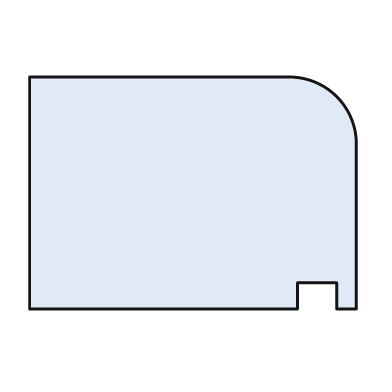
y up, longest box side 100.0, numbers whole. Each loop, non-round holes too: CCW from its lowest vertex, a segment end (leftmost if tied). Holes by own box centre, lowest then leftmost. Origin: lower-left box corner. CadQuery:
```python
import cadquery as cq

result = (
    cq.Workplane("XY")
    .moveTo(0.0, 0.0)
    .lineTo(82.0, 0.0)
    .lineTo(82.0, 8.0)
    .lineTo(94.0, 8.0)
    .lineTo(94.0, 0.0)
    .lineTo(100.0, 0.0)
    .lineTo(100.0, 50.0)
    .threePointArc((94.0, 65.0), (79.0, 71.0))
    .lineTo(0.0, 71.0)
    .close()
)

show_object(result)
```